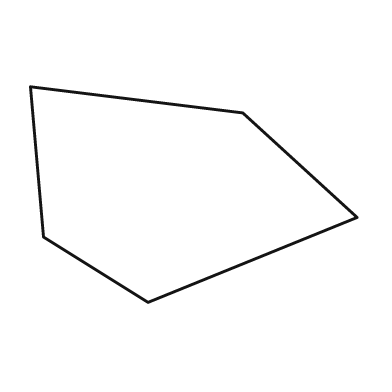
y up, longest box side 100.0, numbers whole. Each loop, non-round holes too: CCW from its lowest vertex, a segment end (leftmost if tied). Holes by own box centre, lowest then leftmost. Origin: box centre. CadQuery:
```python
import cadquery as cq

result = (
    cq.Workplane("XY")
    .moveTo(-14.0, -33.0)
    .lineTo(50.0, -7.0)
    .lineTo(15.0, 25.0)
    .lineTo(-50.0, 33.0)
    .lineTo(-46.0, -13.0)
    .close()
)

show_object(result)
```